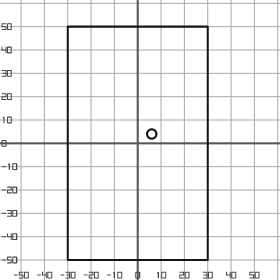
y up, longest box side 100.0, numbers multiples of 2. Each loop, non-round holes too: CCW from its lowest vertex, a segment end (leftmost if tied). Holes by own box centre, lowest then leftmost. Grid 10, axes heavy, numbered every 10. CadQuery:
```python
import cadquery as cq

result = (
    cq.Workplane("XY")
    .moveTo(-30.0, -50.0)
    .lineTo(30.0, -50.0)
    .lineTo(30.0, 50.0)
    .lineTo(-30.0, 50.0)
    .close()
    .moveTo(6.0, 4.0)
    .circle(2.0)
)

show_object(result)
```